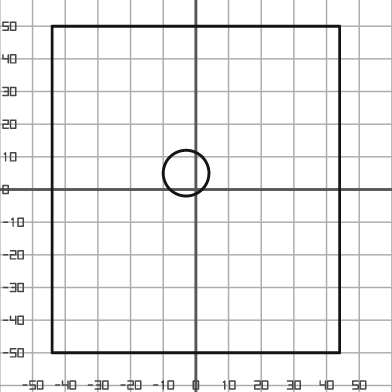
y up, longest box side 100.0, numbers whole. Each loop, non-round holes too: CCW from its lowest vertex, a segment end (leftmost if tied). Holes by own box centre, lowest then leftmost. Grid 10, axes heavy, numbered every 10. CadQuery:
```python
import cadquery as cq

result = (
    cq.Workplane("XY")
    .moveTo(-44.0, -50.0)
    .lineTo(44.0, -50.0)
    .lineTo(44.0, 50.0)
    .lineTo(-44.0, 50.0)
    .close()
    .moveTo(-3.0, 5.0)
    .circle(7.0)
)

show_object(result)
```